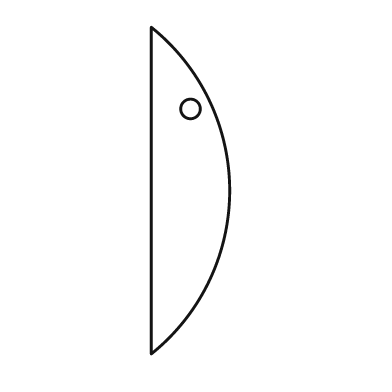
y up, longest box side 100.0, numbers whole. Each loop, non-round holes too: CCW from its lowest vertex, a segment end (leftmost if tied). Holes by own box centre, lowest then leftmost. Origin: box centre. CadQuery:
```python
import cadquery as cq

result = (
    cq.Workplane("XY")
    .moveTo(-12.0, -50.0)
    .threePointArc((12.0, 0.0), (-12.0, 50.0))
    .close()
    .moveTo(0.0, 25.0)
    .circle(3.0)
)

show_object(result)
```